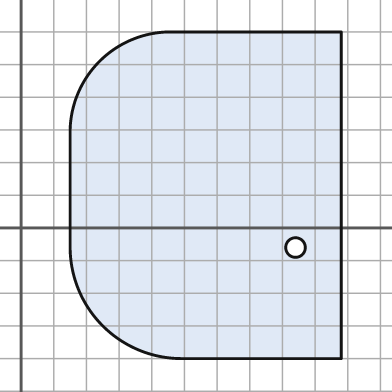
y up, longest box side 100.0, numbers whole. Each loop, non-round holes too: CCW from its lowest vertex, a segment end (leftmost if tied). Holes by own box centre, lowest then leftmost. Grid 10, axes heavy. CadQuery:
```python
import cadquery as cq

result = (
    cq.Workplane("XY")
    .moveTo(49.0, -40.0)
    .lineTo(98.0, -40.0)
    .lineTo(98.0, 60.0)
    .lineTo(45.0, 60.0)
    .threePointArc((24.0, 51.0), (15.0, 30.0))
    .lineTo(15.0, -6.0)
    .threePointArc((25.0, -30.0), (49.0, -40.0))
    .close()
    .moveTo(84.0, -6.0)
    .circle(3.0)
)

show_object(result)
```